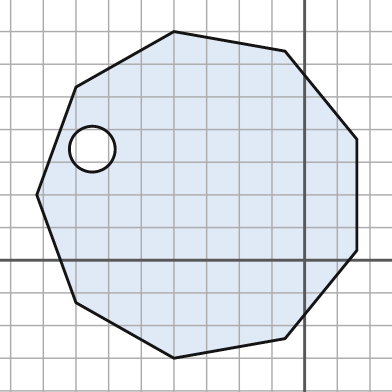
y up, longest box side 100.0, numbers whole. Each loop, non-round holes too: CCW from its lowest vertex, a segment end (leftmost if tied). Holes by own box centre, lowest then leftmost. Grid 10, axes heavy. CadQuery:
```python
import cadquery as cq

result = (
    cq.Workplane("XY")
    .moveTo(-40.0, -30.0)
    .lineTo(-6.0, -24.0)
    .lineTo(16.0, 3.0)
    .lineTo(16.0, 37.0)
    .lineTo(-6.0, 64.0)
    .lineTo(-40.0, 70.0)
    .lineTo(-70.0, 53.0)
    .lineTo(-82.0, 20.0)
    .lineTo(-70.0, -13.0)
    .close()
    .moveTo(-65.0, 34.0)
    .circle(7.0)
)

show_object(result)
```